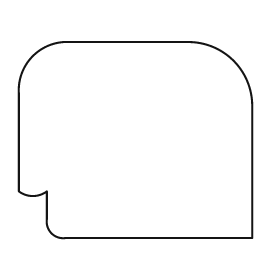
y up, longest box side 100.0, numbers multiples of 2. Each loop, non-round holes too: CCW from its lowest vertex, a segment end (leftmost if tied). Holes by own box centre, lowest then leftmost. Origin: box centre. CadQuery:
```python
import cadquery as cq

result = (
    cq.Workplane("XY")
    .moveTo(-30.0, -42.0)
    .lineTo(50.0, -42.0)
    .lineTo(50.0, 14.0)
    .threePointArc((42.0, 34.0), (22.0, 42.0))
    .lineTo(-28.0, 42.0)
    .threePointArc((-44.0, 36.0), (-50.0, 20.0))
    .lineTo(-50.0, -22.0)
    .threePointArc((-44.0, -24.0), (-38.0, -22.0))
    .lineTo(-38.0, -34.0)
    .threePointArc((-36.0, -40.0), (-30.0, -42.0))
    .close()
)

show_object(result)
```